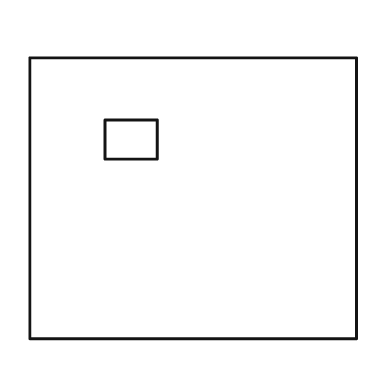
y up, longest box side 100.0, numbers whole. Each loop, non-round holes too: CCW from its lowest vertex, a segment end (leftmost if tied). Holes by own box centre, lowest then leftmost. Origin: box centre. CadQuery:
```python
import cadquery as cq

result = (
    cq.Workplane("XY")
    .moveTo(-50.0, -43.0)
    .lineTo(50.0, -43.0)
    .lineTo(50.0, 43.0)
    .lineTo(-50.0, 43.0)
    .close()
    .moveTo(-27.0, 12.0)
    .lineTo(-11.0, 12.0)
    .lineTo(-11.0, 24.0)
    .lineTo(-27.0, 24.0)
    .close()
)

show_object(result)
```